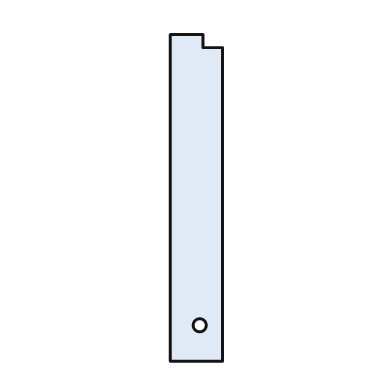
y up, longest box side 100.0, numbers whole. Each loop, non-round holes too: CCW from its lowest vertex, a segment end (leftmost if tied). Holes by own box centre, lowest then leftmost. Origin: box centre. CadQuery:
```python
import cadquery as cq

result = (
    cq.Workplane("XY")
    .moveTo(-8.0, -50.0)
    .lineTo(8.0, -50.0)
    .lineTo(8.0, 46.0)
    .lineTo(2.0, 46.0)
    .lineTo(2.0, 50.0)
    .lineTo(-8.0, 50.0)
    .close()
    .moveTo(1.0, -39.0)
    .circle(2.0)
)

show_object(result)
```